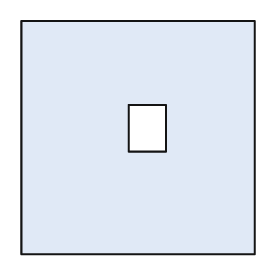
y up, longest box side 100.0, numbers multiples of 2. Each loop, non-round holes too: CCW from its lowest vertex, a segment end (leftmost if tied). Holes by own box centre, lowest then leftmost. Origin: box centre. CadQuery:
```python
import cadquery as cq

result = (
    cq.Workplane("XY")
    .moveTo(-50.0, -50.0)
    .lineTo(50.0, -50.0)
    .lineTo(50.0, 50.0)
    .lineTo(-50.0, 50.0)
    .close()
    .moveTo(-4.0, -6.0)
    .lineTo(12.0, -6.0)
    .lineTo(12.0, 14.0)
    .lineTo(-4.0, 14.0)
    .close()
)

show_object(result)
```